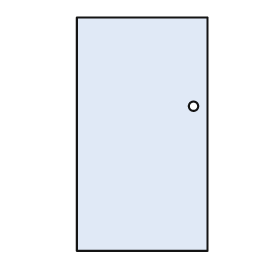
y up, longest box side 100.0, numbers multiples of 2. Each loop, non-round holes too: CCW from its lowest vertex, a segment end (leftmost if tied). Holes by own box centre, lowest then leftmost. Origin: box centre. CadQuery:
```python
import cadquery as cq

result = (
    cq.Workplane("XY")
    .moveTo(-28.0, -50.0)
    .lineTo(28.0, -50.0)
    .lineTo(28.0, 50.0)
    .lineTo(-28.0, 50.0)
    .close()
    .moveTo(22.0, 12.0)
    .circle(2.0)
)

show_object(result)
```